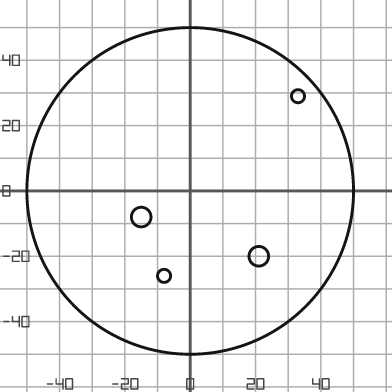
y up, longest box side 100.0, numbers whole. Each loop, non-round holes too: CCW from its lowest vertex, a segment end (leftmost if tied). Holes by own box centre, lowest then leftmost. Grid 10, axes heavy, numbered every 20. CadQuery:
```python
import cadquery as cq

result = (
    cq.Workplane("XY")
    .moveTo(0.0, 0.0)
    .circle(50.0)
    .moveTo(-8.0, -26.0)
    .circle(2.0)
    .moveTo(21.0, -20.0)
    .circle(3.0)
    .moveTo(-15.0, -8.0)
    .circle(3.0)
    .moveTo(33.0, 29.0)
    .circle(2.0)
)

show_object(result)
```